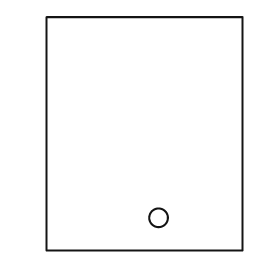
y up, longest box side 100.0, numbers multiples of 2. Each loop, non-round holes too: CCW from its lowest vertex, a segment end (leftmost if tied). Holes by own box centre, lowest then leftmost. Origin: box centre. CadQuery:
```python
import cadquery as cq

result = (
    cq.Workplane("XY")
    .moveTo(-42.0, -50.0)
    .lineTo(42.0, -50.0)
    .lineTo(42.0, 50.0)
    .lineTo(-42.0, 50.0)
    .close()
    .moveTo(6.0, -36.0)
    .circle(4.0)
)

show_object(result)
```